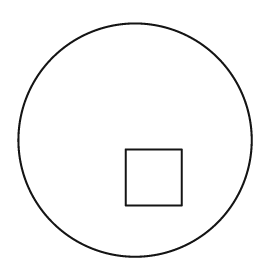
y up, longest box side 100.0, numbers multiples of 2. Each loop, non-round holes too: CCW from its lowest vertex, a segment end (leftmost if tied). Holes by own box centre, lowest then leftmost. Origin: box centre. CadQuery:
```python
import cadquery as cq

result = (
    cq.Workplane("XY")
    .moveTo(0.0, 0.0)
    .circle(50.0)
    .moveTo(-4.0, -28.0)
    .lineTo(20.0, -28.0)
    .lineTo(20.0, -4.0)
    .lineTo(-4.0, -4.0)
    .close()
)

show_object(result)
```